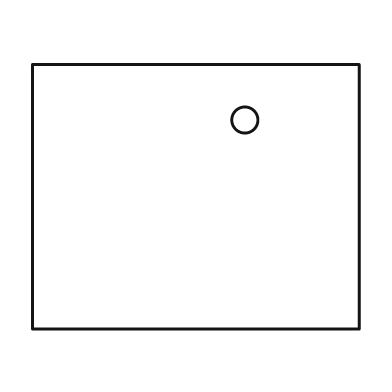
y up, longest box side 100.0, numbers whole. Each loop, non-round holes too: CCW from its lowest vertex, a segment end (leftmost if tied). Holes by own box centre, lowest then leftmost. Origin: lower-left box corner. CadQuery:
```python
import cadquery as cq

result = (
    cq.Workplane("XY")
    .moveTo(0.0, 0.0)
    .lineTo(100.0, 0.0)
    .lineTo(100.0, 81.0)
    .lineTo(0.0, 81.0)
    .close()
    .moveTo(65.0, 64.0)
    .circle(4.0)
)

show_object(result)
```